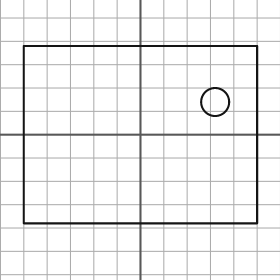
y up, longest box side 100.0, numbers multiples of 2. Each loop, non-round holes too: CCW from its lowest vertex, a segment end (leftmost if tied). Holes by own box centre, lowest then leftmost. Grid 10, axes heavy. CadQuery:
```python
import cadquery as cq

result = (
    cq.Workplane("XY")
    .moveTo(-50.0, -38.0)
    .lineTo(50.0, -38.0)
    .lineTo(50.0, 38.0)
    .lineTo(-50.0, 38.0)
    .close()
    .moveTo(32.0, 14.0)
    .circle(6.0)
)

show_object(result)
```